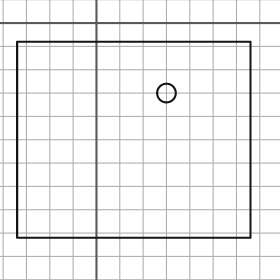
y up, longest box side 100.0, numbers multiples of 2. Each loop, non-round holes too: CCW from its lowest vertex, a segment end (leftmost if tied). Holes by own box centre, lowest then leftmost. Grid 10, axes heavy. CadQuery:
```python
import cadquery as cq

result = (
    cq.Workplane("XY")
    .moveTo(-34.0, -92.0)
    .lineTo(66.0, -92.0)
    .lineTo(66.0, -8.0)
    .lineTo(-34.0, -8.0)
    .close()
    .moveTo(30.0, -30.0)
    .circle(4.0)
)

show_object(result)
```